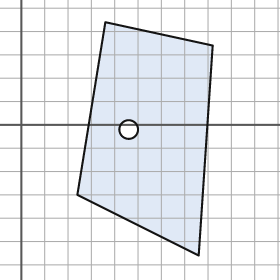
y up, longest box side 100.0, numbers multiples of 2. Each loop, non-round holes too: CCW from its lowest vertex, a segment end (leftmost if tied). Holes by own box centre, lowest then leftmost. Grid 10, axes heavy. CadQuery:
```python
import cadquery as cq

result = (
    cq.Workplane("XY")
    .moveTo(76.0, -56.0)
    .lineTo(82.0, 34.0)
    .lineTo(36.0, 44.0)
    .lineTo(24.0, -30.0)
    .close()
    .moveTo(46.0, -2.0)
    .circle(4.0)
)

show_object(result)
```